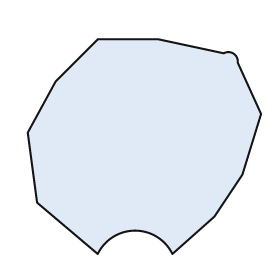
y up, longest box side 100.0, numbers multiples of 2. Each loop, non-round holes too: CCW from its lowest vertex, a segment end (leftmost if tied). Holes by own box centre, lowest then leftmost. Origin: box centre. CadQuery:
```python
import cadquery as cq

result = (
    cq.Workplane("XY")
    .moveTo(-20.0, -46.0)
    .threePointArc((-4.0, -36.0), (12.0, -46.0))
    .lineTo(30.0, -30.0)
    .lineTo(42.0, -12.0)
    .lineTo(50.0, 14.0)
    .lineTo(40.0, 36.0)
    .threePointArc((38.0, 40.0), (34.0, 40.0))
    .lineTo(6.0, 46.0)
    .lineTo(-20.0, 46.0)
    .lineTo(-38.0, 28.0)
    .lineTo(-50.0, 6.0)
    .lineTo(-46.0, -24.0)
    .close()
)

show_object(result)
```